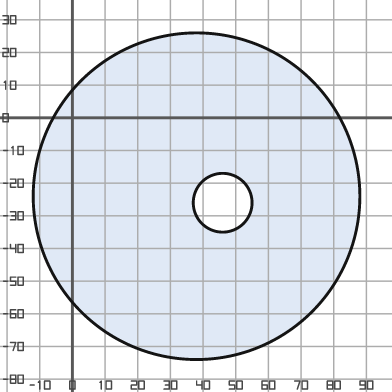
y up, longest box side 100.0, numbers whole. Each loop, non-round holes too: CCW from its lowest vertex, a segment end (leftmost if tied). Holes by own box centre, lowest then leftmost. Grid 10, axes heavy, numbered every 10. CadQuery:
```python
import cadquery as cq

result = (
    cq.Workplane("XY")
    .moveTo(38.0, -24.0)
    .circle(50.0)
    .moveTo(46.0, -26.0)
    .circle(9.0)
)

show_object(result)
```